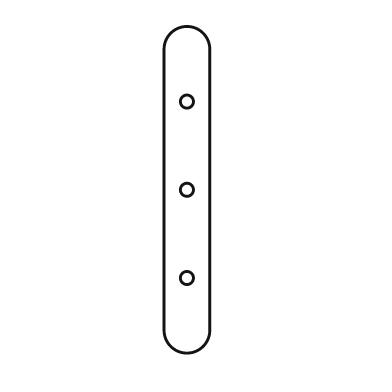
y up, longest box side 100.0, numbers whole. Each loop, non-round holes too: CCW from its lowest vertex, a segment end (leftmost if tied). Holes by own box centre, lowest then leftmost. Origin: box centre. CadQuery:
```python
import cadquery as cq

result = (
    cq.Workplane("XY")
    .moveTo(-7.0, -43.0)
    .threePointArc((0.0, -50.0), (7.0, -43.0))
    .lineTo(7.0, 43.0)
    .threePointArc((0.0, 50.0), (-7.0, 43.0))
    .close()
    .moveTo(0.0, -27.0)
    .circle(2.0)
    .moveTo(0.0, 0.0)
    .circle(2.0)
    .moveTo(0.0, 27.0)
    .circle(2.0)
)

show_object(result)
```